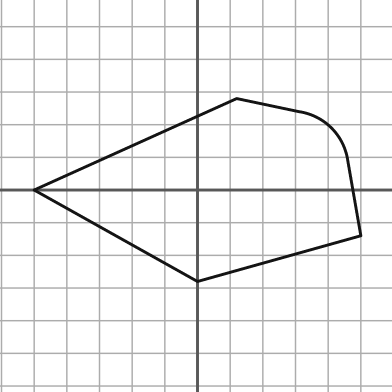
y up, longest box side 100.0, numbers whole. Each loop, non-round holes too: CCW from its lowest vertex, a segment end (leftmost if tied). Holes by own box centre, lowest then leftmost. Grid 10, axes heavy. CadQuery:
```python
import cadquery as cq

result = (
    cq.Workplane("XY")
    .moveTo(0.0, -28.0)
    .lineTo(50.0, -14.0)
    .lineTo(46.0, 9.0)
    .threePointArc((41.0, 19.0), (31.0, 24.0))
    .lineTo(12.0, 28.0)
    .lineTo(-50.0, 0.0)
    .close()
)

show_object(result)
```